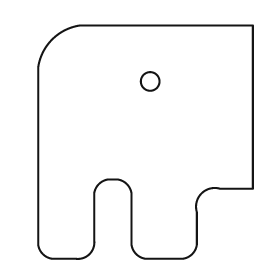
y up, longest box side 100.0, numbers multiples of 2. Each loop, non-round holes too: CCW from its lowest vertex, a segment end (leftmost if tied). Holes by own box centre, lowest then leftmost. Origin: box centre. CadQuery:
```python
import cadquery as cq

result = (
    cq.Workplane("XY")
    .moveTo(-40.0, -50.0)
    .lineTo(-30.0, -50.0)
    .threePointArc((-24.0, -48.0), (-22.0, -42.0))
    .lineTo(-22.0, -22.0)
    .threePointArc((-20.0, -18.0), (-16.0, -16.0))
    .lineTo(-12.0, -16.0)
    .threePointArc((-8.0, -18.0), (-6.0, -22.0))
    .lineTo(-6.0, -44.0)
    .threePointArc((-4.0, -48.0), (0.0, -50.0))
    .lineTo(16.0, -50.0)
    .threePointArc((20.0, -48.0), (22.0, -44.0))
    .lineTo(22.0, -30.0)
    .threePointArc((24.0, -22.0), (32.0, -20.0))
    .lineTo(46.0, -20.0)
    .lineTo(46.0, 50.0)
    .lineTo(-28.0, 50.0)
    .threePointArc((-40.0, 44.0), (-46.0, 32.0))
    .lineTo(-46.0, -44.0)
    .threePointArc((-44.0, -48.0), (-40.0, -50.0))
    .close()
    .moveTo(2.0, 26.0)
    .circle(4.0)
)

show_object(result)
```